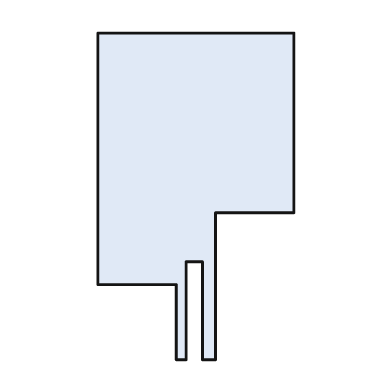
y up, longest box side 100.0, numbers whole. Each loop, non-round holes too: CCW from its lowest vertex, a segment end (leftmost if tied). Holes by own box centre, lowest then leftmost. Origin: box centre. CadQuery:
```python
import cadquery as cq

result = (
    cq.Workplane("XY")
    .moveTo(-6.0, -50.0)
    .lineTo(-3.0, -50.0)
    .lineTo(-3.0, -20.0)
    .lineTo(2.0, -20.0)
    .lineTo(2.0, -50.0)
    .lineTo(6.0, -50.0)
    .lineTo(6.0, -5.0)
    .lineTo(30.0, -5.0)
    .lineTo(30.0, 50.0)
    .lineTo(-30.0, 50.0)
    .lineTo(-30.0, -27.0)
    .lineTo(-6.0, -27.0)
    .close()
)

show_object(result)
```